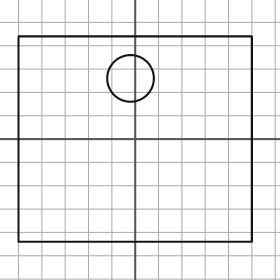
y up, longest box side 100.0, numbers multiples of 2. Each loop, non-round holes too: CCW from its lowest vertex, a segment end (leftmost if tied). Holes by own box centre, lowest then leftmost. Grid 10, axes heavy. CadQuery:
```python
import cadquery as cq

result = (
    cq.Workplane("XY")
    .moveTo(-50.0, -44.0)
    .lineTo(50.0, -44.0)
    .lineTo(50.0, 44.0)
    .lineTo(-50.0, 44.0)
    .close()
    .moveTo(-2.0, 26.0)
    .circle(10.0)
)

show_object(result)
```